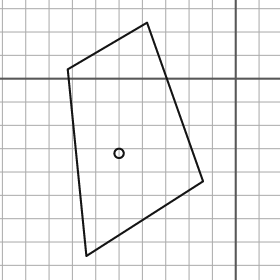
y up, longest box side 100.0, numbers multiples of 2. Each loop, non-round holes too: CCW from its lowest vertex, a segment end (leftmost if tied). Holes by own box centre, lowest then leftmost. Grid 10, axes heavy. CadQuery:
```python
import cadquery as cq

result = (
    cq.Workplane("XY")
    .moveTo(-64.0, -76.0)
    .lineTo(-14.0, -44.0)
    .lineTo(-38.0, 24.0)
    .lineTo(-72.0, 4.0)
    .close()
    .moveTo(-50.0, -32.0)
    .circle(2.0)
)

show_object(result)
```